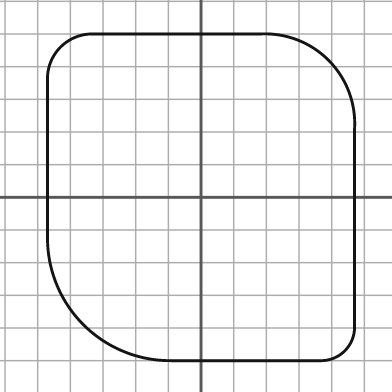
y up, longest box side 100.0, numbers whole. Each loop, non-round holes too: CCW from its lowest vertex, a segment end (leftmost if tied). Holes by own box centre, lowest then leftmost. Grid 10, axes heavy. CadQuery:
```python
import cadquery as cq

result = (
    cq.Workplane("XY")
    .moveTo(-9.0, -50.0)
    .lineTo(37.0, -50.0)
    .threePointArc((44.0, -47.0), (47.0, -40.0))
    .lineTo(47.0, 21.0)
    .threePointArc((39.0, 42.0), (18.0, 50.0))
    .lineTo(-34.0, 50.0)
    .threePointArc((-43.0, 46.0), (-47.0, 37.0))
    .lineTo(-47.0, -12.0)
    .threePointArc((-36.0, -39.0), (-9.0, -50.0))
    .close()
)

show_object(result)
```